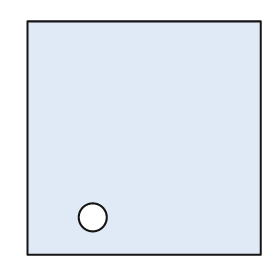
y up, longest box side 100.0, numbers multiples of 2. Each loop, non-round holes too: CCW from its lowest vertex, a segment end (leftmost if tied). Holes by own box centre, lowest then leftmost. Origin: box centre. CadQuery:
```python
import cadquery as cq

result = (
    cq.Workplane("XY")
    .moveTo(-50.0, -50.0)
    .lineTo(50.0, -50.0)
    .lineTo(50.0, 50.0)
    .lineTo(-50.0, 50.0)
    .close()
    .moveTo(-22.0, -34.0)
    .circle(6.0)
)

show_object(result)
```